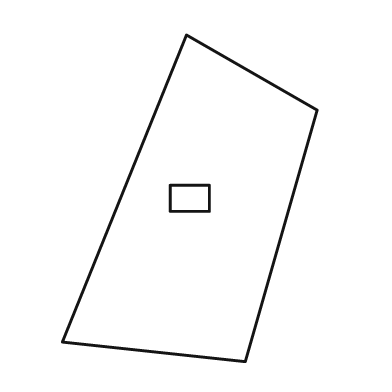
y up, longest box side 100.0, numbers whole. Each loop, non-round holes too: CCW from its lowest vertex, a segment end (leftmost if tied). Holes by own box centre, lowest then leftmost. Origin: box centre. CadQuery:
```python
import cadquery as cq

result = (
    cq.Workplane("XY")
    .moveTo(17.0, -50.0)
    .lineTo(39.0, 27.0)
    .lineTo(-1.0, 50.0)
    .lineTo(-39.0, -44.0)
    .close()
    .moveTo(-6.0, -4.0)
    .lineTo(6.0, -4.0)
    .lineTo(6.0, 4.0)
    .lineTo(-6.0, 4.0)
    .close()
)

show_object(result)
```